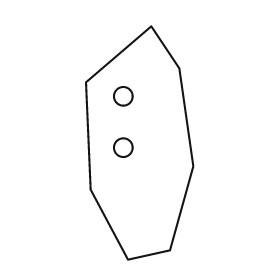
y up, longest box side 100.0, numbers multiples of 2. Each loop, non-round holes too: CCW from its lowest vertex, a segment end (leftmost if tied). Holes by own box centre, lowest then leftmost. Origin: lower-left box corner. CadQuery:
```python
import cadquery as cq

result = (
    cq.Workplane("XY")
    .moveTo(18.0, 0.0)
    .lineTo(36.0, 4.0)
    .lineTo(46.0, 40.0)
    .lineTo(40.0, 82.0)
    .lineTo(28.0, 100.0)
    .lineTo(0.0, 76.0)
    .lineTo(2.0, 30.0)
    .close()
    .moveTo(16.0, 48.0)
    .circle(4.0)
    .moveTo(16.0, 70.0)
    .circle(4.0)
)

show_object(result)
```